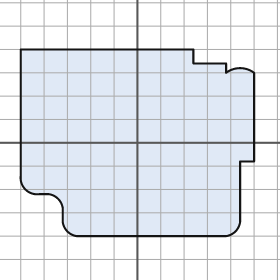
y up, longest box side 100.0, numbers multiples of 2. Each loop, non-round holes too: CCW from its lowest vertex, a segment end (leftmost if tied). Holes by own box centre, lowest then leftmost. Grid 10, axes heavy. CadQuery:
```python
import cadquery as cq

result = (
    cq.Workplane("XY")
    .moveTo(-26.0, -40.0)
    .lineTo(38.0, -40.0)
    .threePointArc((42.0, -38.0), (44.0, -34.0))
    .lineTo(44.0, -8.0)
    .lineTo(50.0, -8.0)
    .lineTo(50.0, 30.0)
    .threePointArc((44.0, 32.0), (38.0, 30.0))
    .lineTo(38.0, 34.0)
    .lineTo(24.0, 34.0)
    .lineTo(24.0, 40.0)
    .lineTo(-50.0, 40.0)
    .lineTo(-50.0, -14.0)
    .threePointArc((-48.0, -20.0), (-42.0, -22.0))
    .lineTo(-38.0, -22.0)
    .threePointArc((-34.0, -24.0), (-32.0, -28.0))
    .lineTo(-32.0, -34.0)
    .threePointArc((-30.0, -38.0), (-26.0, -40.0))
    .close()
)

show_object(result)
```